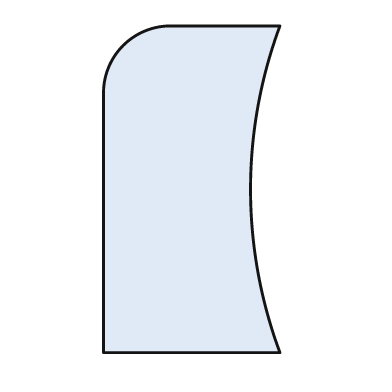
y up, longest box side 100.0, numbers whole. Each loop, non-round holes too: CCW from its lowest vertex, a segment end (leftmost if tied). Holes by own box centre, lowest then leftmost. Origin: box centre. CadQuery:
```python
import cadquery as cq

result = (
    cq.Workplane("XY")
    .moveTo(-27.0, -50.0)
    .lineTo(27.0, -50.0)
    .threePointArc((18.0, 0.0), (27.0, 50.0))
    .lineTo(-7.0, 50.0)
    .threePointArc((-21.0, 44.0), (-27.0, 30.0))
    .close()
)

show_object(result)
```